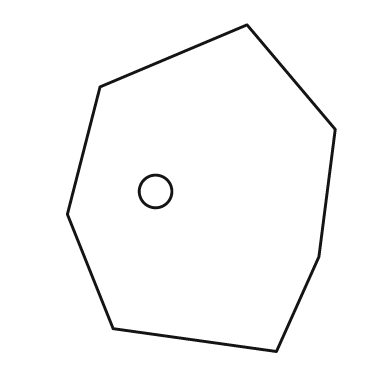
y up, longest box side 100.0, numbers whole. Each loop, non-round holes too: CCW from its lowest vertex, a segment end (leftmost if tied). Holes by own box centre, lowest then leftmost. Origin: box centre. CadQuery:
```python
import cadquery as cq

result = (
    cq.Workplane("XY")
    .moveTo(23.0, -50.0)
    .lineTo(36.0, -21.0)
    .lineTo(41.0, 18.0)
    .lineTo(14.0, 50.0)
    .lineTo(-31.0, 31.0)
    .lineTo(-41.0, -8.0)
    .lineTo(-27.0, -43.0)
    .close()
    .moveTo(-14.0, -1.0)
    .circle(5.0)
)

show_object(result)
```